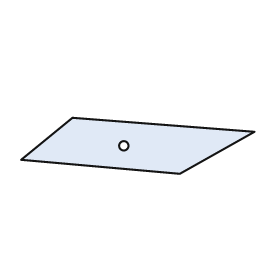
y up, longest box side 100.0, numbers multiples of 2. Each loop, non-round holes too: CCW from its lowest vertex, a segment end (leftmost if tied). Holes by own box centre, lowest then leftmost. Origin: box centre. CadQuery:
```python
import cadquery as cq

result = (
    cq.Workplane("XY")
    .moveTo(18.0, -12.0)
    .lineTo(50.0, 6.0)
    .lineTo(-28.0, 12.0)
    .lineTo(-50.0, -6.0)
    .close()
    .moveTo(-6.0, 0.0)
    .circle(2.0)
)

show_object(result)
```